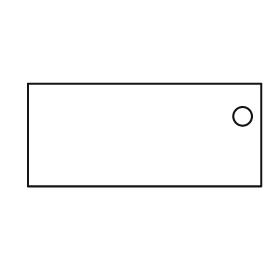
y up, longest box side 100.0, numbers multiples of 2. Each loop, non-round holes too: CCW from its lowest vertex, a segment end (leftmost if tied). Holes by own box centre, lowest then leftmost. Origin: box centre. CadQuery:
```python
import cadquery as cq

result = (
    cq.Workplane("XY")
    .moveTo(-50.0, -22.0)
    .lineTo(50.0, -22.0)
    .lineTo(50.0, 22.0)
    .lineTo(-50.0, 22.0)
    .close()
    .moveTo(42.0, 8.0)
    .circle(4.0)
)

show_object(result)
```